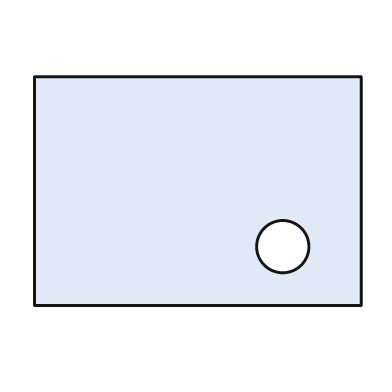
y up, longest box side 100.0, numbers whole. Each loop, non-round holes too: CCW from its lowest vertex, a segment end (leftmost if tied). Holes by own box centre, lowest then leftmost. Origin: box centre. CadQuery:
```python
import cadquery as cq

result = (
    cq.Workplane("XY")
    .moveTo(-50.0, -35.0)
    .lineTo(50.0, -35.0)
    .lineTo(50.0, 35.0)
    .lineTo(-50.0, 35.0)
    .close()
    .moveTo(26.0, -17.0)
    .circle(8.0)
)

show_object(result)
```